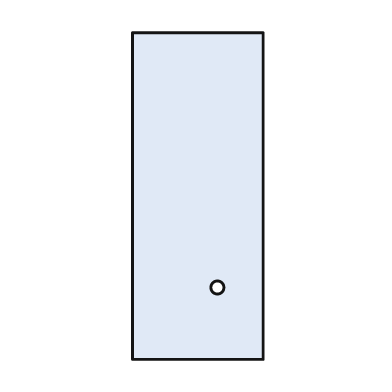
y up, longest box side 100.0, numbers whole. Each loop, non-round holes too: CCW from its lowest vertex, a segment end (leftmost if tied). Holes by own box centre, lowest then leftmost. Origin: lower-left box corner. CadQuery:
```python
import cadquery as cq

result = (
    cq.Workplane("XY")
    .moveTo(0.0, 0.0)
    .lineTo(40.0, 0.0)
    .lineTo(40.0, 100.0)
    .lineTo(0.0, 100.0)
    .close()
    .moveTo(26.0, 22.0)
    .circle(2.0)
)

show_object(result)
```